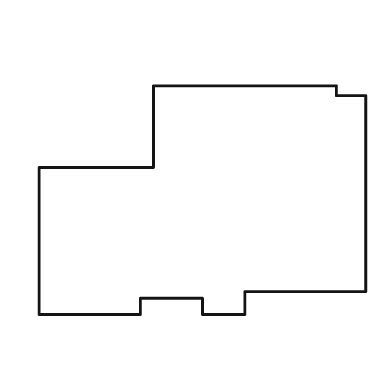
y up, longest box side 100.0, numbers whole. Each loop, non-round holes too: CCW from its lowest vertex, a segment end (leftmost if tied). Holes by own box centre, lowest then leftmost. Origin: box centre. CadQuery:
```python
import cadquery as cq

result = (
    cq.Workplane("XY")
    .moveTo(-50.0, -35.0)
    .lineTo(-19.0, -35.0)
    .lineTo(-19.0, -30.0)
    .lineTo(0.0, -30.0)
    .lineTo(0.0, -35.0)
    .lineTo(13.0, -35.0)
    .lineTo(13.0, -28.0)
    .lineTo(50.0, -28.0)
    .lineTo(50.0, 32.0)
    .lineTo(41.0, 32.0)
    .lineTo(41.0, 35.0)
    .lineTo(-15.0, 35.0)
    .lineTo(-15.0, 10.0)
    .lineTo(-50.0, 10.0)
    .close()
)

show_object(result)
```